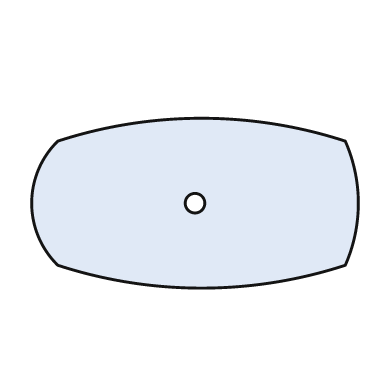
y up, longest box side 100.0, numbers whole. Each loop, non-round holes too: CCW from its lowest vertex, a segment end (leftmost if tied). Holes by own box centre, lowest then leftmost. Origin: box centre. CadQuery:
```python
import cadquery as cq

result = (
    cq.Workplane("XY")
    .moveTo(-42.0, -19.0)
    .threePointArc((2.0, -26.0), (46.0, -19.0))
    .threePointArc((50.0, 0.0), (46.0, 19.0))
    .threePointArc((2.0, 26.0), (-42.0, 19.0))
    .threePointArc((-50.0, 0.0), (-42.0, -19.0))
    .close()
    .moveTo(0.0, 0.0)
    .circle(3.0)
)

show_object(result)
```